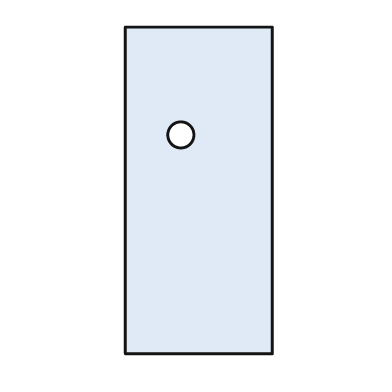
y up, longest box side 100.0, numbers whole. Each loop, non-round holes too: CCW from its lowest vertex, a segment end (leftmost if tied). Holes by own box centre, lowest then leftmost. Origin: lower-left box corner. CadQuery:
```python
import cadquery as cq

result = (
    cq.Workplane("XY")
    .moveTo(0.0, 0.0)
    .lineTo(45.0, 0.0)
    .lineTo(45.0, 100.0)
    .lineTo(0.0, 100.0)
    .close()
    .moveTo(17.0, 67.0)
    .circle(4.0)
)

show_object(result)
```